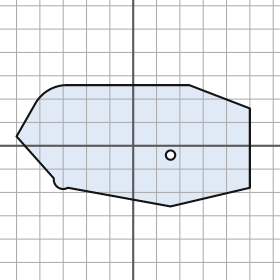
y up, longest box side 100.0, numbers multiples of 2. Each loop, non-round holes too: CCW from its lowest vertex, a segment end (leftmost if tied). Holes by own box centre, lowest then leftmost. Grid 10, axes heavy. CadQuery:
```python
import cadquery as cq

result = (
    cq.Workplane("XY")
    .moveTo(16.0, -26.0)
    .lineTo(50.0, -18.0)
    .lineTo(50.0, 16.0)
    .lineTo(24.0, 26.0)
    .lineTo(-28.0, 26.0)
    .threePointArc((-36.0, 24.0), (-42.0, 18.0))
    .lineTo(-50.0, 4.0)
    .lineTo(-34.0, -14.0)
    .threePointArc((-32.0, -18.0), (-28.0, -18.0))
    .close()
    .moveTo(16.0, -4.0)
    .circle(2.0)
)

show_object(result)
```